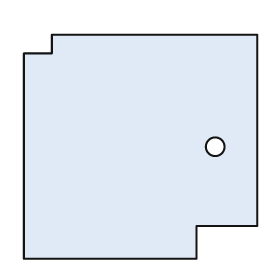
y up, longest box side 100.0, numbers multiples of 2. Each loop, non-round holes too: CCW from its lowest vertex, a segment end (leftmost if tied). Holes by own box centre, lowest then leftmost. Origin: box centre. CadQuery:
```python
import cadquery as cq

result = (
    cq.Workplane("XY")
    .moveTo(-50.0, -48.0)
    .lineTo(24.0, -48.0)
    .lineTo(24.0, -34.0)
    .lineTo(50.0, -34.0)
    .lineTo(50.0, 48.0)
    .lineTo(-38.0, 48.0)
    .lineTo(-38.0, 40.0)
    .lineTo(-50.0, 40.0)
    .close()
    .moveTo(32.0, 0.0)
    .circle(4.0)
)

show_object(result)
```